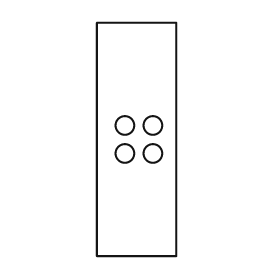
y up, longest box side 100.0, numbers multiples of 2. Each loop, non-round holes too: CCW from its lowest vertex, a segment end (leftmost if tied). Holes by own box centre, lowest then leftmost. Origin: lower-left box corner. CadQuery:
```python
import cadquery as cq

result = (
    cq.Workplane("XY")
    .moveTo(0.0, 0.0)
    .lineTo(34.0, 0.0)
    .lineTo(34.0, 100.0)
    .lineTo(0.0, 100.0)
    .close()
    .moveTo(12.0, 44.0)
    .circle(4.0)
    .moveTo(24.0, 44.0)
    .circle(4.0)
    .moveTo(12.0, 56.0)
    .circle(4.0)
    .moveTo(24.0, 56.0)
    .circle(4.0)
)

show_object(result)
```